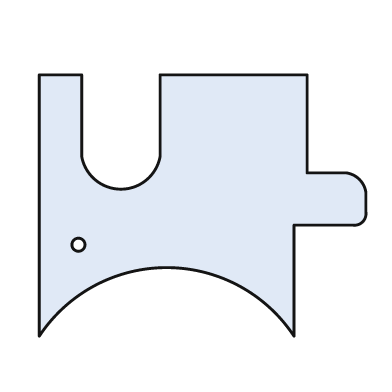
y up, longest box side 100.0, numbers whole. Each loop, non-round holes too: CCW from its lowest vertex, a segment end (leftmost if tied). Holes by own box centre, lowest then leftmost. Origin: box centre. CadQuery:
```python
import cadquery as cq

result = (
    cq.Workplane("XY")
    .moveTo(-50.0, -40.0)
    .threePointArc((-11.0, -19.0), (28.0, -40.0))
    .lineTo(28.0, -6.0)
    .lineTo(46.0, -6.0)
    .threePointArc((49.0, -5.0), (50.0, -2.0))
    .lineTo(50.0, 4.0)
    .threePointArc((48.0, 8.0), (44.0, 10.0))
    .lineTo(32.0, 10.0)
    .lineTo(32.0, 40.0)
    .lineTo(-13.0, 40.0)
    .lineTo(-13.0, 15.0)
    .threePointArc((-25.0, 5.0), (-37.0, 15.0))
    .lineTo(-37.0, 40.0)
    .lineTo(-50.0, 40.0)
    .close()
    .moveTo(-38.0, -12.0)
    .circle(2.0)
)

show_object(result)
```